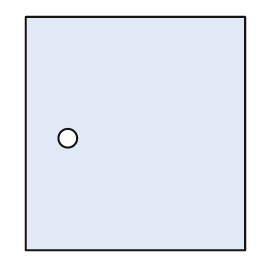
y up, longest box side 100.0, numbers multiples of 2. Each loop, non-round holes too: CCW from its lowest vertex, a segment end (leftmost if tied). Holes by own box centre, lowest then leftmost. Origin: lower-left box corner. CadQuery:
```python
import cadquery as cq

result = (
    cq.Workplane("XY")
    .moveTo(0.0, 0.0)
    .lineTo(94.0, 0.0)
    .lineTo(94.0, 100.0)
    .lineTo(0.0, 100.0)
    .close()
    .moveTo(18.0, 48.0)
    .circle(4.0)
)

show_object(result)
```